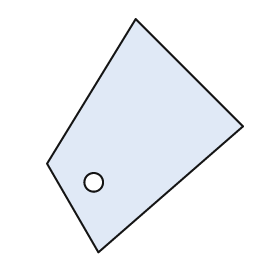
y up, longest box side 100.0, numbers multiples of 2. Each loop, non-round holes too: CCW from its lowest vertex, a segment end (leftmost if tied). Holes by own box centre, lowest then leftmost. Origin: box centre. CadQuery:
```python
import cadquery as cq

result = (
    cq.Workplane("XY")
    .moveTo(-20.0, -50.0)
    .lineTo(42.0, 4.0)
    .lineTo(-4.0, 50.0)
    .lineTo(-42.0, -12.0)
    .close()
    .moveTo(-22.0, -20.0)
    .circle(4.0)
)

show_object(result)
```